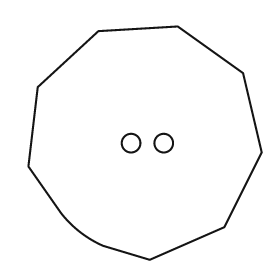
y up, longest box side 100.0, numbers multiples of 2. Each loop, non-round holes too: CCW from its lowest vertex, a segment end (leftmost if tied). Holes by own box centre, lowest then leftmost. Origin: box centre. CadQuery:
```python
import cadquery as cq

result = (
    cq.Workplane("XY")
    .moveTo(2.0, -50.0)
    .lineTo(34.0, -36.0)
    .lineTo(50.0, -4.0)
    .lineTo(42.0, 30.0)
    .lineTo(14.0, 50.0)
    .lineTo(-20.0, 48.0)
    .lineTo(-46.0, 24.0)
    .lineTo(-50.0, -10.0)
    .lineTo(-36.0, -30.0)
    .threePointArc((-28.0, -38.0), (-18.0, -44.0))
    .close()
    .moveTo(-6.0, 0.0)
    .circle(4.0)
    .moveTo(8.0, 0.0)
    .circle(4.0)
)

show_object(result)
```